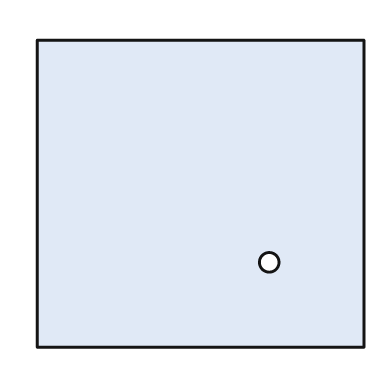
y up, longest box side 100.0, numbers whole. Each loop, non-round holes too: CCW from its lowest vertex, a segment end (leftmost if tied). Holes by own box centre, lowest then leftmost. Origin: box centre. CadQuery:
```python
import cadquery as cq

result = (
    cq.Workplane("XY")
    .moveTo(-50.0, -47.0)
    .lineTo(50.0, -47.0)
    .lineTo(50.0, 47.0)
    .lineTo(-50.0, 47.0)
    .close()
    .moveTo(21.0, -21.0)
    .circle(3.0)
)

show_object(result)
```